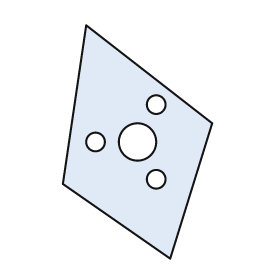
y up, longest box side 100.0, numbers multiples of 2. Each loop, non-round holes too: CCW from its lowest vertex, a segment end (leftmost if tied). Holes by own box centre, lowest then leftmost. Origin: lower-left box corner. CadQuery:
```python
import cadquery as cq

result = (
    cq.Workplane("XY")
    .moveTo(46.0, 0.0)
    .lineTo(64.0, 58.0)
    .lineTo(10.0, 100.0)
    .lineTo(0.0, 32.0)
    .close()
    .moveTo(40.0, 34.0)
    .circle(4.0)
    .moveTo(14.0, 50.0)
    .circle(4.0)
    .moveTo(32.0, 50.0)
    .circle(8.0)
    .moveTo(40.0, 66.0)
    .circle(4.0)
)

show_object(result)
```